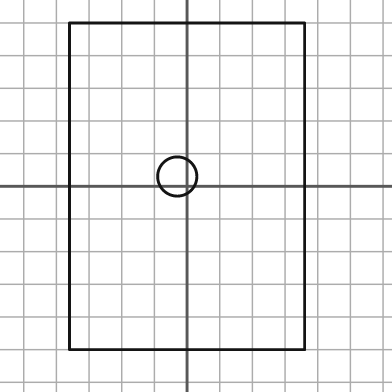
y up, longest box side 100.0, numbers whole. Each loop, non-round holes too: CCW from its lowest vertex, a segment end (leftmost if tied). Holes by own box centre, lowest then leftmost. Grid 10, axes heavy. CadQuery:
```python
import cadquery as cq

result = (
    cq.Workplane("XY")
    .moveTo(-36.0, -50.0)
    .lineTo(36.0, -50.0)
    .lineTo(36.0, 50.0)
    .lineTo(-36.0, 50.0)
    .close()
    .moveTo(-3.0, 3.0)
    .circle(6.0)
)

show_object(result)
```